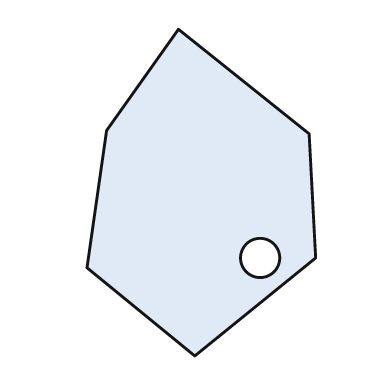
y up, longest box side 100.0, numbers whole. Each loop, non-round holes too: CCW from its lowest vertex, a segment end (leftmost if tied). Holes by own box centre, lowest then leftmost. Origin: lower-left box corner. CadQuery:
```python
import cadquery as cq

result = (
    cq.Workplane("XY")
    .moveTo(33.0, 0.0)
    .lineTo(70.0, 30.0)
    .lineTo(68.0, 68.0)
    .lineTo(28.0, 100.0)
    .lineTo(6.0, 69.0)
    .lineTo(0.0, 27.0)
    .close()
    .moveTo(53.0, 30.0)
    .circle(6.0)
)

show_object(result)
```